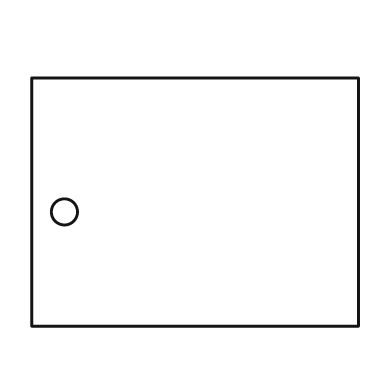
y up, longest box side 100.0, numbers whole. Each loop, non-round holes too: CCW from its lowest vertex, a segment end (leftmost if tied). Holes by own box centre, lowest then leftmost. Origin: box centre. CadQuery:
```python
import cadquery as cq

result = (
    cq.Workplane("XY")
    .moveTo(-50.0, -38.0)
    .lineTo(50.0, -38.0)
    .lineTo(50.0, 38.0)
    .lineTo(-50.0, 38.0)
    .close()
    .moveTo(-40.0, -3.0)
    .circle(4.0)
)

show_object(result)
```